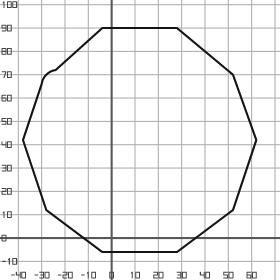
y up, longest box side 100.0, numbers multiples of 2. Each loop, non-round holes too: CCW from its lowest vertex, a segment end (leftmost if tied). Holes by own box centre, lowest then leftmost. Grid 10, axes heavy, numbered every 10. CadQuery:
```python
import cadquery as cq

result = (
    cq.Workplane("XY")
    .moveTo(-4.0, -6.0)
    .lineTo(28.0, -6.0)
    .lineTo(52.0, 12.0)
    .lineTo(62.0, 42.0)
    .lineTo(52.0, 70.0)
    .lineTo(28.0, 90.0)
    .lineTo(-4.0, 90.0)
    .lineTo(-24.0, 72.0)
    .threePointArc((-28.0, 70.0), (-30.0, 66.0))
    .lineTo(-38.0, 42.0)
    .lineTo(-28.0, 12.0)
    .close()
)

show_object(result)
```